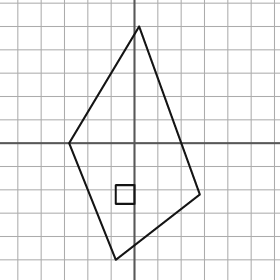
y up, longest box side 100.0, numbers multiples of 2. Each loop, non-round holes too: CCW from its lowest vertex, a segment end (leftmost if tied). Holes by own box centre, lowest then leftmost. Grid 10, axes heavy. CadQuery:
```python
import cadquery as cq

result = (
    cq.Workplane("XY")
    .moveTo(-8.0, -50.0)
    .lineTo(28.0, -22.0)
    .lineTo(2.0, 50.0)
    .lineTo(-28.0, 0.0)
    .close()
    .moveTo(-8.0, -26.0)
    .lineTo(0.0, -26.0)
    .lineTo(0.0, -18.0)
    .lineTo(-8.0, -18.0)
    .close()
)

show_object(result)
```